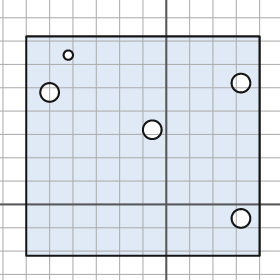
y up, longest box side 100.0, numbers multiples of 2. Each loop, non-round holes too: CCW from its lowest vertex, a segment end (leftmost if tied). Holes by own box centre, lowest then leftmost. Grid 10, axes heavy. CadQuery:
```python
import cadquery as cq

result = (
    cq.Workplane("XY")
    .moveTo(-60.0, -22.0)
    .lineTo(40.0, -22.0)
    .lineTo(40.0, 72.0)
    .lineTo(-60.0, 72.0)
    .close()
    .moveTo(32.0, -6.0)
    .circle(4.0)
    .moveTo(-6.0, 32.0)
    .circle(4.0)
    .moveTo(-50.0, 48.0)
    .circle(4.0)
    .moveTo(32.0, 52.0)
    .circle(4.0)
    .moveTo(-42.0, 64.0)
    .circle(2.0)
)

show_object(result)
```